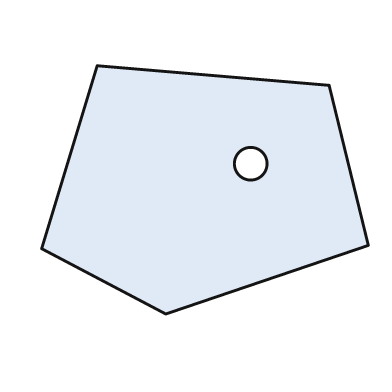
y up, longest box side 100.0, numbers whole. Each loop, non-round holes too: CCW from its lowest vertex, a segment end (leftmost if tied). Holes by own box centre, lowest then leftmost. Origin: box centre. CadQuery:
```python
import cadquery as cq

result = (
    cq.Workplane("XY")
    .moveTo(-12.0, -38.0)
    .lineTo(50.0, -17.0)
    .lineTo(38.0, 32.0)
    .lineTo(-33.0, 38.0)
    .lineTo(-50.0, -18.0)
    .close()
    .moveTo(14.0, 8.0)
    .circle(5.0)
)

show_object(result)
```